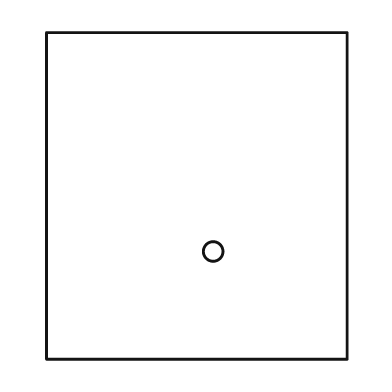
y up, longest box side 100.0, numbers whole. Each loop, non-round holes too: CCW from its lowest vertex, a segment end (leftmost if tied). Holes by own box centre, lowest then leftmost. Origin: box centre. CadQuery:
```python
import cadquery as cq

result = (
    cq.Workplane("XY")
    .moveTo(-46.0, -50.0)
    .lineTo(46.0, -50.0)
    .lineTo(46.0, 50.0)
    .lineTo(-46.0, 50.0)
    .close()
    .moveTo(5.0, -17.0)
    .circle(3.0)
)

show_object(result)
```